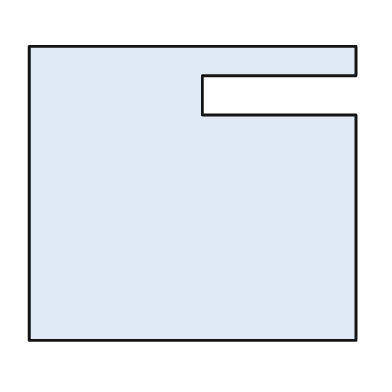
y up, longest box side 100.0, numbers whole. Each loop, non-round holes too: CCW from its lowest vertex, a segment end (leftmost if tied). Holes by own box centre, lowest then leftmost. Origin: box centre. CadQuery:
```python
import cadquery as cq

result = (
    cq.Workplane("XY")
    .moveTo(-50.0, -45.0)
    .lineTo(50.0, -45.0)
    .lineTo(50.0, 24.0)
    .lineTo(3.0, 24.0)
    .lineTo(3.0, 36.0)
    .lineTo(50.0, 36.0)
    .lineTo(50.0, 45.0)
    .lineTo(-50.0, 45.0)
    .close()
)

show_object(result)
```